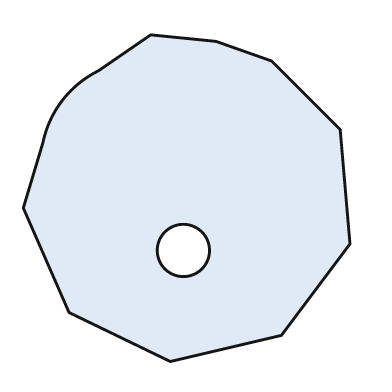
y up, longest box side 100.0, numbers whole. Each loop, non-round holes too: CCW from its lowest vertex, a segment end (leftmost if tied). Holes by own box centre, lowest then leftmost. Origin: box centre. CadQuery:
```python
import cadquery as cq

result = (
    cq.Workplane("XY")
    .moveTo(-5.0, -50.0)
    .lineTo(29.0, -42.0)
    .lineTo(50.0, -14.0)
    .lineTo(47.0, 21.0)
    .lineTo(26.0, 42.0)
    .lineTo(9.0, 48.0)
    .lineTo(-11.0, 50.0)
    .lineTo(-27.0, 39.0)
    .threePointArc((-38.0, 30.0), (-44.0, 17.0))
    .lineTo(-50.0, -3.0)
    .lineTo(-36.0, -35.0)
    .close()
    .moveTo(-1.0, -16.0)
    .circle(8.0)
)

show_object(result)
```